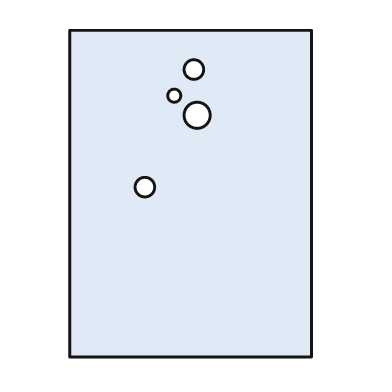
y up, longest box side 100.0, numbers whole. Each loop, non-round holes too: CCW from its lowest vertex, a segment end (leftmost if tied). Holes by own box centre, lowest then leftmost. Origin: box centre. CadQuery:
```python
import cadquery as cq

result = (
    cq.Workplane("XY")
    .moveTo(-37.0, -50.0)
    .lineTo(37.0, -50.0)
    .lineTo(37.0, 50.0)
    .lineTo(-37.0, 50.0)
    .close()
    .moveTo(-14.0, 2.0)
    .circle(3.0)
    .moveTo(2.0, 24.0)
    .circle(4.0)
    .moveTo(-5.0, 30.0)
    .circle(2.0)
    .moveTo(1.0, 38.0)
    .circle(3.0)
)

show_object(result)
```